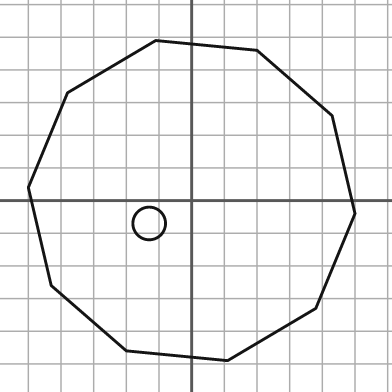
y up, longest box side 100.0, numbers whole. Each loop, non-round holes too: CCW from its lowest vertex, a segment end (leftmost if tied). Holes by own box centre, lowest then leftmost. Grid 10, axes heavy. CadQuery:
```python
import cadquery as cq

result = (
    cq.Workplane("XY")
    .moveTo(11.0, -49.0)
    .lineTo(38.0, -33.0)
    .lineTo(50.0, -4.0)
    .lineTo(43.0, 26.0)
    .lineTo(20.0, 46.0)
    .lineTo(-11.0, 49.0)
    .lineTo(-38.0, 33.0)
    .lineTo(-50.0, 4.0)
    .lineTo(-43.0, -26.0)
    .lineTo(-20.0, -46.0)
    .close()
    .moveTo(-13.0, -7.0)
    .circle(5.0)
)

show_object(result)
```